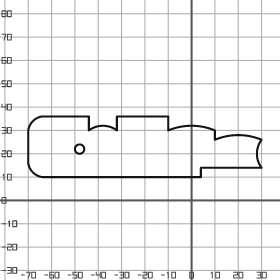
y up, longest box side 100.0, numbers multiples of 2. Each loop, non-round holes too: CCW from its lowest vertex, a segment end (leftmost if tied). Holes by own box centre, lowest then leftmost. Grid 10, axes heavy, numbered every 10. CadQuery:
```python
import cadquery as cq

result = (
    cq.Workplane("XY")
    .moveTo(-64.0, 10.0)
    .lineTo(4.0, 10.0)
    .lineTo(4.0, 14.0)
    .lineTo(30.0, 14.0)
    .threePointArc((28.0, 20.0), (30.0, 26.0))
    .threePointArc((20.0, 28.0), (10.0, 26.0))
    .lineTo(10.0, 30.0)
    .threePointArc((0.0, 32.0), (-10.0, 30.0))
    .lineTo(-10.0, 36.0)
    .lineTo(-32.0, 36.0)
    .lineTo(-32.0, 30.0)
    .threePointArc((-38.0, 32.0), (-44.0, 30.0))
    .lineTo(-44.0, 36.0)
    .lineTo(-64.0, 36.0)
    .threePointArc((-68.0, 34.0), (-70.0, 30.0))
    .lineTo(-70.0, 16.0)
    .threePointArc((-68.0, 12.0), (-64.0, 10.0))
    .close()
    .moveTo(-48.0, 22.0)
    .circle(2.0)
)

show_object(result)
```